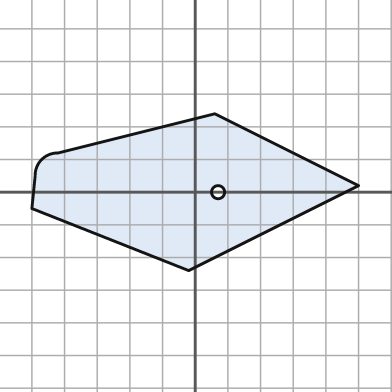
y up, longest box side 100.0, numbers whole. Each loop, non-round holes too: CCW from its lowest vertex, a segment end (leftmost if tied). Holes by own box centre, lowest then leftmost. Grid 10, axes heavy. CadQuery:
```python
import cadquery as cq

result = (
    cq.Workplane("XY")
    .moveTo(-2.0, -24.0)
    .lineTo(50.0, 2.0)
    .lineTo(6.0, 24.0)
    .lineTo(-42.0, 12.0)
    .threePointArc((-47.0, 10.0), (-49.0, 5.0))
    .lineTo(-50.0, -5.0)
    .close()
    .moveTo(7.0, 0.0)
    .circle(2.0)
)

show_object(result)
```